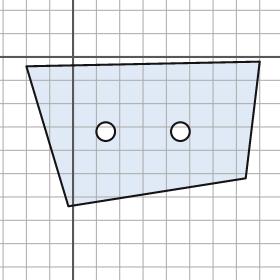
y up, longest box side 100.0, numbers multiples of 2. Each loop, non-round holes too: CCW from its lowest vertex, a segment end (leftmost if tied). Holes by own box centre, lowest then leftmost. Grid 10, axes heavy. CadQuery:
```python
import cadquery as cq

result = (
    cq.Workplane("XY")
    .moveTo(-2.0, -64.0)
    .lineTo(74.0, -52.0)
    .lineTo(80.0, -2.0)
    .lineTo(-20.0, -4.0)
    .close()
    .moveTo(14.0, -32.0)
    .circle(4.0)
    .moveTo(46.0, -32.0)
    .circle(4.0)
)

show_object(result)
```